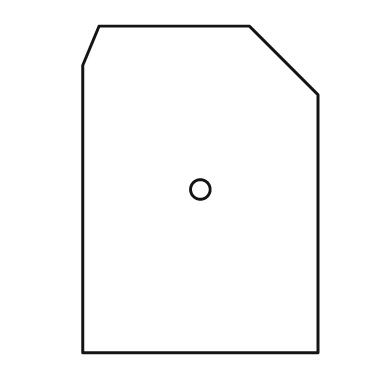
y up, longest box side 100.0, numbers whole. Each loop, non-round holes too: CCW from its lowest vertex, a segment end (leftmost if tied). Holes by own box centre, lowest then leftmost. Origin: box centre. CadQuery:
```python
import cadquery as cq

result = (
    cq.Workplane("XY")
    .moveTo(-36.0, -50.0)
    .lineTo(36.0, -50.0)
    .lineTo(36.0, 29.0)
    .lineTo(15.0, 50.0)
    .lineTo(-31.0, 50.0)
    .lineTo(-36.0, 38.0)
    .close()
    .moveTo(0.0, 0.0)
    .circle(3.0)
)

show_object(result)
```